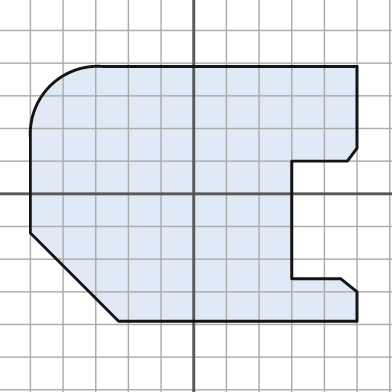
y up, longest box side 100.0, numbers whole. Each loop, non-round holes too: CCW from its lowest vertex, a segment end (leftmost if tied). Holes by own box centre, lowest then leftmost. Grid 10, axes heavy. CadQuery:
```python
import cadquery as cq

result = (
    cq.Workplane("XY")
    .moveTo(-23.0, -39.0)
    .lineTo(50.0, -39.0)
    .lineTo(50.0, -30.0)
    .lineTo(45.0, -26.0)
    .lineTo(30.0, -26.0)
    .lineTo(30.0, 10.0)
    .lineTo(47.0, 10.0)
    .lineTo(50.0, 14.0)
    .lineTo(50.0, 39.0)
    .lineTo(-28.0, 39.0)
    .threePointArc((-44.0, 33.0), (-50.0, 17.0))
    .lineTo(-50.0, -12.0)
    .close()
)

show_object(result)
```